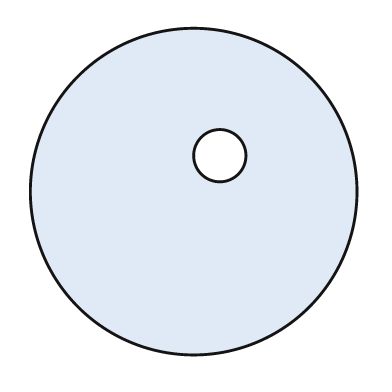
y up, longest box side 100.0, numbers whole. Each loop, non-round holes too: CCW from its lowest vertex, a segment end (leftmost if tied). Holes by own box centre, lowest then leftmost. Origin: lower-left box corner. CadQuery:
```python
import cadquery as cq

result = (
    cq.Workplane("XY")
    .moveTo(50.0, 50.0)
    .circle(50.0)
    .moveTo(58.0, 61.0)
    .circle(8.0)
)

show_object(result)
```